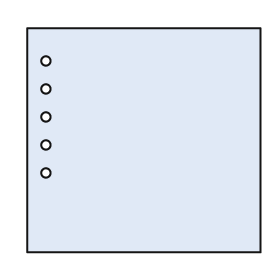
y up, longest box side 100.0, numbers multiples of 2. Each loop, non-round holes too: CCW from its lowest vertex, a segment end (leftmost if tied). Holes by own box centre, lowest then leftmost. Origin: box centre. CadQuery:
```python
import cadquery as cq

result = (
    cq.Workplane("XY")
    .moveTo(-50.0, -48.0)
    .lineTo(50.0, -48.0)
    .lineTo(50.0, 48.0)
    .lineTo(-50.0, 48.0)
    .close()
    .moveTo(-42.0, -14.0)
    .circle(2.0)
    .moveTo(-42.0, -2.0)
    .circle(2.0)
    .moveTo(-42.0, 10.0)
    .circle(2.0)
    .moveTo(-42.0, 22.0)
    .circle(2.0)
    .moveTo(-42.0, 34.0)
    .circle(2.0)
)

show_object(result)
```